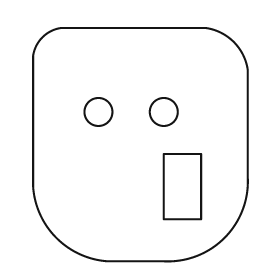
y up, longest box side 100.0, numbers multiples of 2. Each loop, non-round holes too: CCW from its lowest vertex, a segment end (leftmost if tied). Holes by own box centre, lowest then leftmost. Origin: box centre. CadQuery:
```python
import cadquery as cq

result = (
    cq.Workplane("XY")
    .moveTo(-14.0, -50.0)
    .lineTo(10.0, -50.0)
    .threePointArc((36.0, -40.0), (46.0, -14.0))
    .lineTo(46.0, 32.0)
    .threePointArc((40.0, 44.0), (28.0, 50.0))
    .lineTo(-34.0, 50.0)
    .threePointArc((-42.0, 46.0), (-46.0, 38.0))
    .lineTo(-46.0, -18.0)
    .threePointArc((-36.0, -40.0), (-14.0, -50.0))
    .close()
    .moveTo(10.0, -32.0)
    .lineTo(26.0, -32.0)
    .lineTo(26.0, -4.0)
    .lineTo(10.0, -4.0)
    .close()
    .moveTo(-18.0, 14.0)
    .circle(6.0)
    .moveTo(10.0, 14.0)
    .circle(6.0)
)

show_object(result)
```